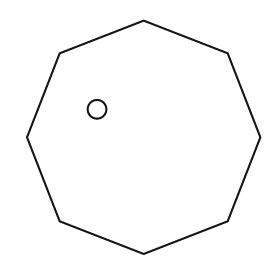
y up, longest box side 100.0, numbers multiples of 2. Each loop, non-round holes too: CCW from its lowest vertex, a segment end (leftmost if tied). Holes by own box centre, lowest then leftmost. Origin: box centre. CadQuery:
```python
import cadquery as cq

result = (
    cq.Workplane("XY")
    .moveTo(0.0, -50.0)
    .lineTo(36.0, -36.0)
    .lineTo(50.0, 0.0)
    .lineTo(36.0, 36.0)
    .lineTo(0.0, 50.0)
    .lineTo(-36.0, 36.0)
    .lineTo(-50.0, 0.0)
    .lineTo(-36.0, -36.0)
    .close()
    .moveTo(-20.0, 12.0)
    .circle(4.0)
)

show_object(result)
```